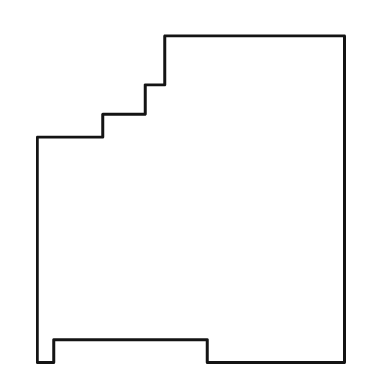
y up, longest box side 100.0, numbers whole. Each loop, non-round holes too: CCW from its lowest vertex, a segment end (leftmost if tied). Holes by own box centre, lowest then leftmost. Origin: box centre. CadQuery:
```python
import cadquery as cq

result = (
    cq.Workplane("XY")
    .moveTo(-47.0, -50.0)
    .lineTo(-42.0, -50.0)
    .lineTo(-42.0, -43.0)
    .lineTo(5.0, -43.0)
    .lineTo(5.0, -50.0)
    .lineTo(47.0, -50.0)
    .lineTo(47.0, 50.0)
    .lineTo(-8.0, 50.0)
    .lineTo(-8.0, 35.0)
    .lineTo(-14.0, 35.0)
    .lineTo(-14.0, 26.0)
    .lineTo(-27.0, 26.0)
    .lineTo(-27.0, 19.0)
    .lineTo(-47.0, 19.0)
    .close()
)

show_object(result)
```